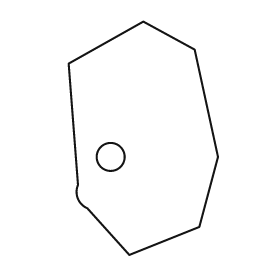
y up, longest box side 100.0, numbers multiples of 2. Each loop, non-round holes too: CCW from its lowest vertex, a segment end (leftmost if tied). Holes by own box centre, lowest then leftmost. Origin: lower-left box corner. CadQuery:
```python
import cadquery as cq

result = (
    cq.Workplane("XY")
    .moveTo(26.0, 0.0)
    .lineTo(56.0, 12.0)
    .lineTo(64.0, 42.0)
    .lineTo(54.0, 88.0)
    .lineTo(32.0, 100.0)
    .lineTo(0.0, 82.0)
    .lineTo(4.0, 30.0)
    .threePointArc((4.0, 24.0), (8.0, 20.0))
    .close()
    .moveTo(18.0, 42.0)
    .circle(6.0)
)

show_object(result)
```